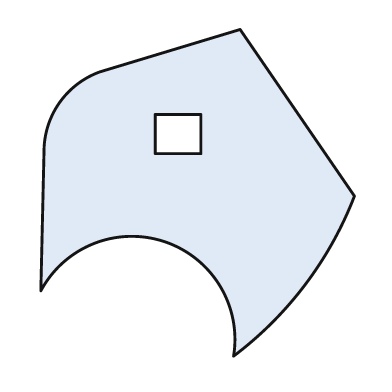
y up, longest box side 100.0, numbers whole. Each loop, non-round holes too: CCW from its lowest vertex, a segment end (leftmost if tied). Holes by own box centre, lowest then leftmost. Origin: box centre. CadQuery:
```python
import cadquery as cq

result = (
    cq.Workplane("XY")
    .moveTo(11.0, -50.0)
    .threePointArc((33.0, -28.0), (48.0, -1.0))
    .lineTo(13.0, 50.0)
    .lineTo(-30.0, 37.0)
    .threePointArc((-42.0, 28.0), (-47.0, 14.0))
    .lineTo(-48.0, -30.0)
    .threePointArc((-10.0, -15.0), (11.0, -50.0))
    .close()
    .moveTo(-13.0, 12.0)
    .lineTo(1.0, 12.0)
    .lineTo(1.0, 24.0)
    .lineTo(-13.0, 24.0)
    .close()
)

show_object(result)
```